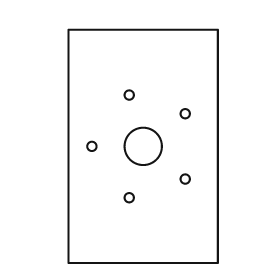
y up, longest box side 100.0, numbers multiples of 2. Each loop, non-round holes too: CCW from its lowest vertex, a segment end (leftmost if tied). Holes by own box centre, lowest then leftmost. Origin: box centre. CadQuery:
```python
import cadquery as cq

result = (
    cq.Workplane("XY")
    .moveTo(-32.0, -50.0)
    .lineTo(32.0, -50.0)
    .lineTo(32.0, 50.0)
    .lineTo(-32.0, 50.0)
    .close()
    .moveTo(-6.0, -22.0)
    .circle(2.0)
    .moveTo(18.0, -14.0)
    .circle(2.0)
    .moveTo(-22.0, 0.0)
    .circle(2.0)
    .moveTo(0.0, 0.0)
    .circle(8.0)
    .moveTo(18.0, 14.0)
    .circle(2.0)
    .moveTo(-6.0, 22.0)
    .circle(2.0)
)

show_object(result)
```